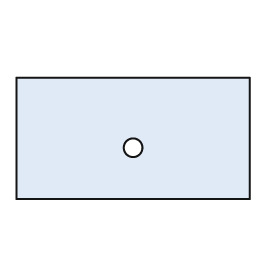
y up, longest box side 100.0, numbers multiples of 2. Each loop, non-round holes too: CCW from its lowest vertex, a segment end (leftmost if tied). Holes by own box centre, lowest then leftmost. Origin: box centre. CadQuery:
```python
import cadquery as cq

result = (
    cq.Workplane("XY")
    .moveTo(-50.0, -26.0)
    .lineTo(50.0, -26.0)
    .lineTo(50.0, 26.0)
    .lineTo(-50.0, 26.0)
    .close()
    .moveTo(0.0, -4.0)
    .circle(4.0)
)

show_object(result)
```